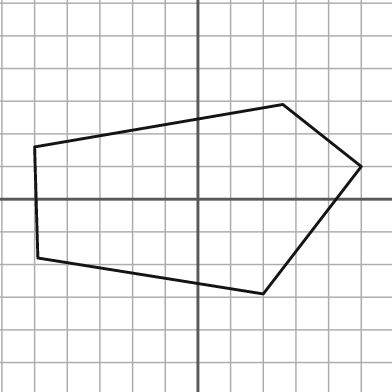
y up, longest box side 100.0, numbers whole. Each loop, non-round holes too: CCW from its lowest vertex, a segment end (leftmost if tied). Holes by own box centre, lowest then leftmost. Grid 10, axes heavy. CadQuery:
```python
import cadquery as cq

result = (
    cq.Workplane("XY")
    .moveTo(20.0, -29.0)
    .lineTo(50.0, 10.0)
    .lineTo(26.0, 29.0)
    .lineTo(-50.0, 16.0)
    .lineTo(-49.0, -18.0)
    .close()
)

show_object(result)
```